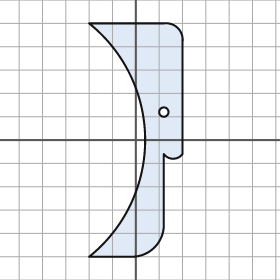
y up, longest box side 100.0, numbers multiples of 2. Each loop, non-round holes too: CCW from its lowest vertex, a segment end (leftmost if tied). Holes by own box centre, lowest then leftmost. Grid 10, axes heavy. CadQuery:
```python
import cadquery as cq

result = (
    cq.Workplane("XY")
    .moveTo(-20.0, -50.0)
    .lineTo(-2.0, -50.0)
    .threePointArc((8.0, -46.0), (12.0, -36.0))
    .lineTo(12.0, -6.0)
    .threePointArc((16.0, -8.0), (20.0, -6.0))
    .lineTo(20.0, 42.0)
    .threePointArc((18.0, 48.0), (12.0, 50.0))
    .lineTo(-20.0, 50.0)
    .threePointArc((4.0, 0.0), (-20.0, -50.0))
    .close()
    .moveTo(12.0, 12.0)
    .circle(2.0)
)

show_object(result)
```